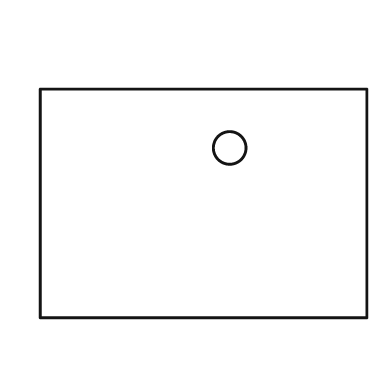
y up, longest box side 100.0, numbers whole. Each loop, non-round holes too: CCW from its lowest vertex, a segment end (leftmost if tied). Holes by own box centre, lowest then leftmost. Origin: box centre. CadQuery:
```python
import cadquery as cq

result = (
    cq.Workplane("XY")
    .moveTo(-50.0, -35.0)
    .lineTo(50.0, -35.0)
    .lineTo(50.0, 35.0)
    .lineTo(-50.0, 35.0)
    .close()
    .moveTo(8.0, 17.0)
    .circle(5.0)
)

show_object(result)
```